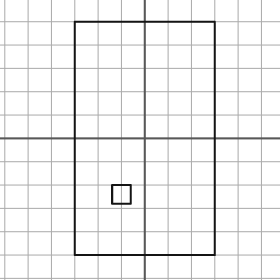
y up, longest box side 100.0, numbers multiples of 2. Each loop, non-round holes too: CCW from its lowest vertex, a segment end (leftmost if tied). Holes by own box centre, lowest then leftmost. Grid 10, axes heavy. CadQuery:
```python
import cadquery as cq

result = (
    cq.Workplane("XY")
    .moveTo(-30.0, -50.0)
    .lineTo(30.0, -50.0)
    .lineTo(30.0, 50.0)
    .lineTo(-30.0, 50.0)
    .close()
    .moveTo(-14.0, -28.0)
    .lineTo(-6.0, -28.0)
    .lineTo(-6.0, -20.0)
    .lineTo(-14.0, -20.0)
    .close()
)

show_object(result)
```